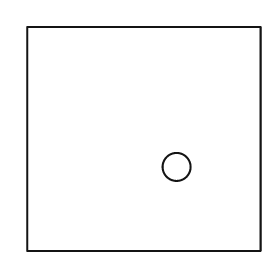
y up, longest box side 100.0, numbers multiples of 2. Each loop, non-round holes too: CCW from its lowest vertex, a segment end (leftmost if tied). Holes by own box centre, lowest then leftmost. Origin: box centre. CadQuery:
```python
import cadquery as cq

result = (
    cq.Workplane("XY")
    .moveTo(-50.0, -48.0)
    .lineTo(50.0, -48.0)
    .lineTo(50.0, 48.0)
    .lineTo(-50.0, 48.0)
    .close()
    .moveTo(14.0, -12.0)
    .circle(6.0)
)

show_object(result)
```